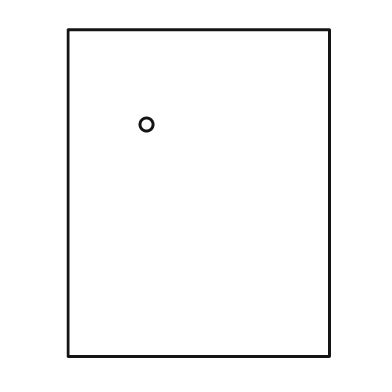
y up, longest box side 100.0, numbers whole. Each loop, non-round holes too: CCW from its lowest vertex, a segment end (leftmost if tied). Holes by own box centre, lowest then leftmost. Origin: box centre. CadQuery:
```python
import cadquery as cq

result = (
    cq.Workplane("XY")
    .moveTo(-40.0, -50.0)
    .lineTo(40.0, -50.0)
    .lineTo(40.0, 50.0)
    .lineTo(-40.0, 50.0)
    .close()
    .moveTo(-16.0, 21.0)
    .circle(2.0)
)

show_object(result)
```